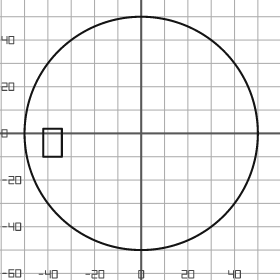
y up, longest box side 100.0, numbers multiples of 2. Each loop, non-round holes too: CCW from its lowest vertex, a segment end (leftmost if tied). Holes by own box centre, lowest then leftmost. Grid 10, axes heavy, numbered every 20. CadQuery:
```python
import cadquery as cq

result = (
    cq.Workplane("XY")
    .moveTo(0.0, 0.0)
    .circle(50.0)
    .moveTo(-42.0, -10.0)
    .lineTo(-34.0, -10.0)
    .lineTo(-34.0, 2.0)
    .lineTo(-42.0, 2.0)
    .close()
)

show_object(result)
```